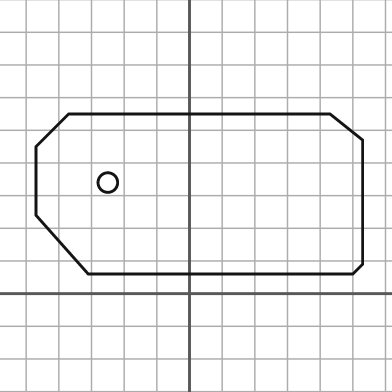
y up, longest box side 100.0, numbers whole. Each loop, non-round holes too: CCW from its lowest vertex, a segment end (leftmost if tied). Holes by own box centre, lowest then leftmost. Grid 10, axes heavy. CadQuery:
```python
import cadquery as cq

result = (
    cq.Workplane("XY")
    .moveTo(-31.0, 6.0)
    .lineTo(50.0, 6.0)
    .lineTo(53.0, 9.0)
    .lineTo(53.0, 47.0)
    .lineTo(43.0, 55.0)
    .lineTo(-37.0, 55.0)
    .lineTo(-47.0, 45.0)
    .lineTo(-47.0, 24.0)
    .close()
    .moveTo(-25.0, 34.0)
    .circle(3.0)
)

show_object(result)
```